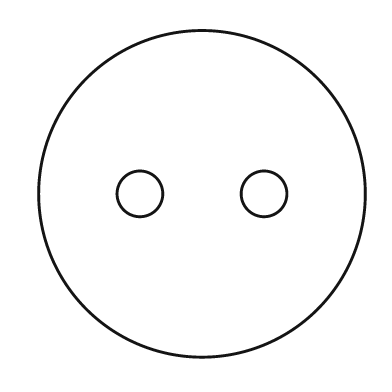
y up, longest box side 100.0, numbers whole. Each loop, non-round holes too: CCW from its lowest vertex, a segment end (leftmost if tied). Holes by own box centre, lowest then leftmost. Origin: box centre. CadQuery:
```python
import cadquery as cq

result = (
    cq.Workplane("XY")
    .moveTo(0.0, 0.0)
    .circle(50.0)
    .moveTo(-19.0, 0.0)
    .circle(7.0)
    .moveTo(19.0, 0.0)
    .circle(7.0)
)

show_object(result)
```